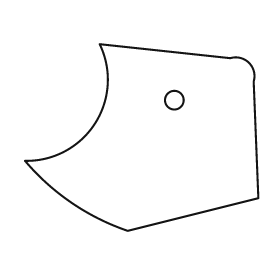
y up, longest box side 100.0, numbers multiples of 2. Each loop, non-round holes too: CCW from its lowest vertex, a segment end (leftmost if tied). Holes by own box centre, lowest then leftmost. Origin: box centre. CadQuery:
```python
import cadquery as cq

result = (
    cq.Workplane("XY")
    .moveTo(-6.0, -40.0)
    .lineTo(50.0, -26.0)
    .lineTo(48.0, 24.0)
    .threePointArc((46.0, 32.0), (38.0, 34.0))
    .lineTo(-18.0, 40.0)
    .threePointArc((-20.0, 6.0), (-50.0, -10.0))
    .threePointArc((-30.0, -28.0), (-6.0, -40.0))
    .close()
    .moveTo(14.0, 16.0)
    .circle(4.0)
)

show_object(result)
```